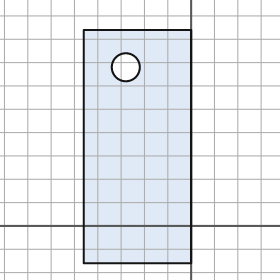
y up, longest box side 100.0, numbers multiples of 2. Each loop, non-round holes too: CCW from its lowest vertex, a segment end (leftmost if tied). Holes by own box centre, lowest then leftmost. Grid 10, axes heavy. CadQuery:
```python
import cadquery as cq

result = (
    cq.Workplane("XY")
    .moveTo(-46.0, -16.0)
    .lineTo(0.0, -16.0)
    .lineTo(0.0, 84.0)
    .lineTo(-46.0, 84.0)
    .close()
    .moveTo(-28.0, 68.0)
    .circle(6.0)
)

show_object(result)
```